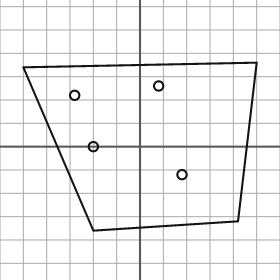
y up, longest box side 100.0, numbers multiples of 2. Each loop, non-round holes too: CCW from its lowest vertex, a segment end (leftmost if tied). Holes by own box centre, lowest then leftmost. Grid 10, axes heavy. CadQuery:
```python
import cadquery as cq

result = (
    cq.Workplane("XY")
    .moveTo(-20.0, -36.0)
    .lineTo(42.0, -32.0)
    .lineTo(50.0, 36.0)
    .lineTo(-50.0, 34.0)
    .close()
    .moveTo(18.0, -12.0)
    .circle(2.0)
    .moveTo(-20.0, 0.0)
    .circle(2.0)
    .moveTo(-28.0, 22.0)
    .circle(2.0)
    .moveTo(8.0, 26.0)
    .circle(2.0)
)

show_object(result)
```